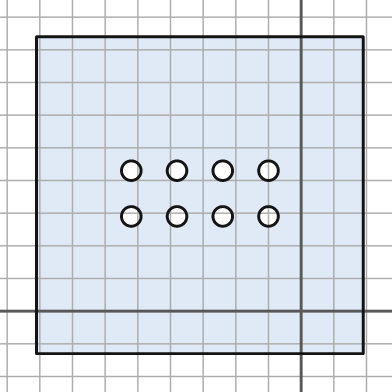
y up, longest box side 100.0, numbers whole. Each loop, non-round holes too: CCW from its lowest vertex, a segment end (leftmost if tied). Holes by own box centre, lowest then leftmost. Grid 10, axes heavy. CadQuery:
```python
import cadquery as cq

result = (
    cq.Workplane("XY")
    .moveTo(-81.0, -13.0)
    .lineTo(19.0, -13.0)
    .lineTo(19.0, 84.0)
    .lineTo(-81.0, 84.0)
    .close()
    .moveTo(-52.0, 29.0)
    .circle(3.0)
    .moveTo(-38.0, 29.0)
    .circle(3.0)
    .moveTo(-24.0, 29.0)
    .circle(3.0)
    .moveTo(-10.0, 29.0)
    .circle(3.0)
    .moveTo(-52.0, 43.0)
    .circle(3.0)
    .moveTo(-38.0, 43.0)
    .circle(3.0)
    .moveTo(-24.0, 43.0)
    .circle(3.0)
    .moveTo(-10.0, 43.0)
    .circle(3.0)
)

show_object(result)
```